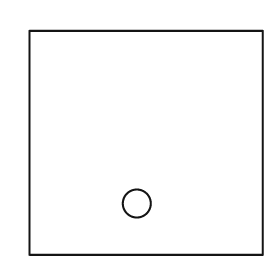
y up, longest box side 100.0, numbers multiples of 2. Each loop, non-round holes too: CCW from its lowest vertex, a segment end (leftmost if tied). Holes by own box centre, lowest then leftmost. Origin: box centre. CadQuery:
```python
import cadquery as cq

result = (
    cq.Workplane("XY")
    .moveTo(-50.0, -48.0)
    .lineTo(50.0, -48.0)
    .lineTo(50.0, 48.0)
    .lineTo(-50.0, 48.0)
    .close()
    .moveTo(-4.0, -26.0)
    .circle(6.0)
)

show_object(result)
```